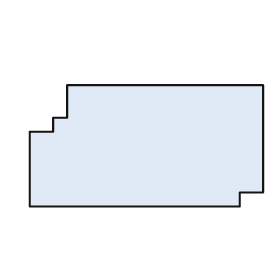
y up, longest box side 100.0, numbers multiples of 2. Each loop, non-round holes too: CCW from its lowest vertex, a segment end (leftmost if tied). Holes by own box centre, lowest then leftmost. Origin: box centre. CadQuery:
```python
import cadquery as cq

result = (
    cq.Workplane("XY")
    .moveTo(-50.0, -26.0)
    .lineTo(40.0, -26.0)
    .lineTo(40.0, -20.0)
    .lineTo(50.0, -20.0)
    .lineTo(50.0, 26.0)
    .lineTo(-34.0, 26.0)
    .lineTo(-34.0, 12.0)
    .lineTo(-40.0, 12.0)
    .lineTo(-40.0, 6.0)
    .lineTo(-50.0, 6.0)
    .close()
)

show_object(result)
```